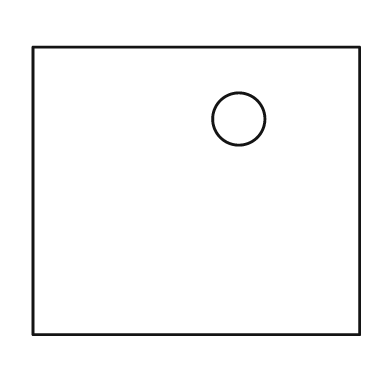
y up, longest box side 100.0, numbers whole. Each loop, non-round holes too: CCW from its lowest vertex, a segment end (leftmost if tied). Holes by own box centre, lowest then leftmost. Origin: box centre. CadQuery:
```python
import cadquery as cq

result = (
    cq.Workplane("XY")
    .moveTo(-50.0, -44.0)
    .lineTo(50.0, -44.0)
    .lineTo(50.0, 44.0)
    .lineTo(-50.0, 44.0)
    .close()
    .moveTo(13.0, 22.0)
    .circle(8.0)
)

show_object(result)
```